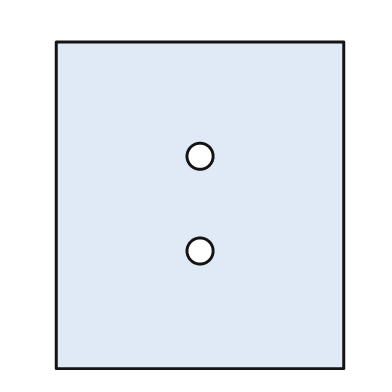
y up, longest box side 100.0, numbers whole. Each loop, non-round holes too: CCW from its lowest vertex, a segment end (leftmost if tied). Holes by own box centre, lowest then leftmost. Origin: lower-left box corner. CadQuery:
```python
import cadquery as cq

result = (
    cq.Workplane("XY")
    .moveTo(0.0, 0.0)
    .lineTo(88.0, 0.0)
    .lineTo(88.0, 100.0)
    .lineTo(0.0, 100.0)
    .close()
    .moveTo(44.0, 36.0)
    .circle(4.0)
    .moveTo(44.0, 65.0)
    .circle(4.0)
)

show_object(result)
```